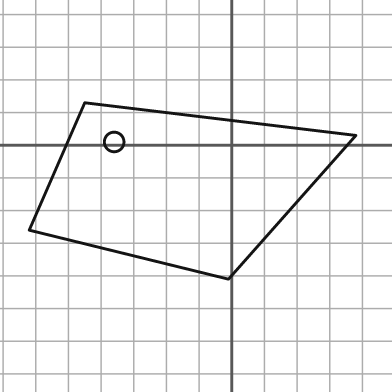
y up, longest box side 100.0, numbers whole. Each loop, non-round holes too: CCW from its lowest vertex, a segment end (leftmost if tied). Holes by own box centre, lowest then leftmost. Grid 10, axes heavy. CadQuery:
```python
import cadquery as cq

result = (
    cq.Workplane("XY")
    .moveTo(-1.0, -41.0)
    .lineTo(38.0, 3.0)
    .lineTo(-45.0, 13.0)
    .lineTo(-62.0, -26.0)
    .close()
    .moveTo(-36.0, 1.0)
    .circle(3.0)
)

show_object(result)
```